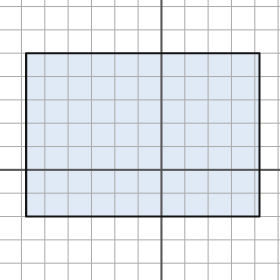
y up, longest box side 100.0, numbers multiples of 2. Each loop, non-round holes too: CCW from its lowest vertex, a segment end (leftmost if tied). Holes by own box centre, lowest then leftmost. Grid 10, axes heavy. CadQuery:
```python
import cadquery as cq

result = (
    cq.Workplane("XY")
    .moveTo(-58.0, -20.0)
    .lineTo(42.0, -20.0)
    .lineTo(42.0, 50.0)
    .lineTo(-58.0, 50.0)
    .close()
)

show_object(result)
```